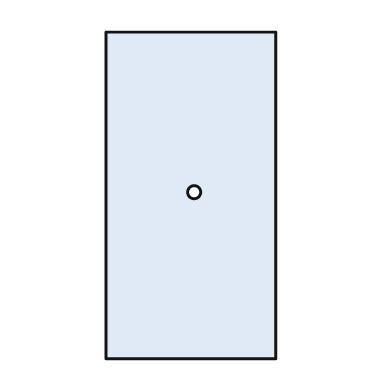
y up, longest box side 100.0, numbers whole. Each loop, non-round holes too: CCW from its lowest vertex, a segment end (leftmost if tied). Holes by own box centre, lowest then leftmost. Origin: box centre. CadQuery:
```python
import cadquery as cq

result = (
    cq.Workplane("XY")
    .moveTo(-26.0, -50.0)
    .lineTo(26.0, -50.0)
    .lineTo(26.0, 50.0)
    .lineTo(-26.0, 50.0)
    .close()
    .moveTo(1.0, 1.0)
    .circle(2.0)
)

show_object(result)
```